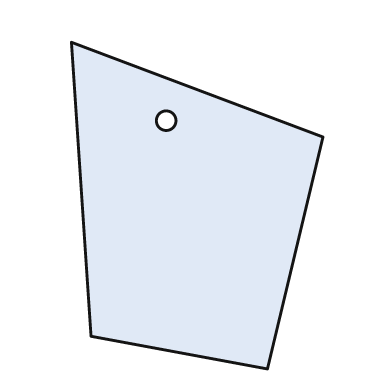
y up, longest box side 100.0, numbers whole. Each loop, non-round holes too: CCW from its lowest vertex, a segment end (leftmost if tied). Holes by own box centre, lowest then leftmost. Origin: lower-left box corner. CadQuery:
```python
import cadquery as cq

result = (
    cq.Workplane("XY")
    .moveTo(60.0, 0.0)
    .lineTo(77.0, 71.0)
    .lineTo(0.0, 100.0)
    .lineTo(6.0, 10.0)
    .close()
    .moveTo(29.0, 76.0)
    .circle(3.0)
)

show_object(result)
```